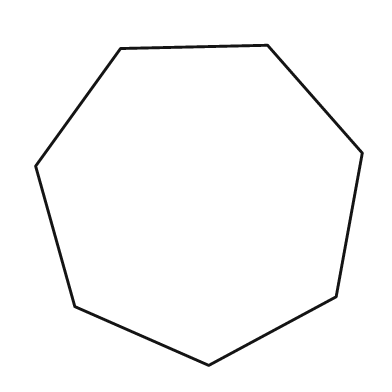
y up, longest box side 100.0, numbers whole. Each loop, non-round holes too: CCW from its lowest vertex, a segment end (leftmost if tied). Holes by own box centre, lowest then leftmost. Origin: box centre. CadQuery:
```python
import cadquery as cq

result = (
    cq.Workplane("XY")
    .moveTo(3.0, -49.0)
    .lineTo(42.0, -28.0)
    .lineTo(50.0, 16.0)
    .lineTo(21.0, 49.0)
    .lineTo(-24.0, 48.0)
    .lineTo(-50.0, 12.0)
    .lineTo(-38.0, -31.0)
    .close()
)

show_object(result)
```